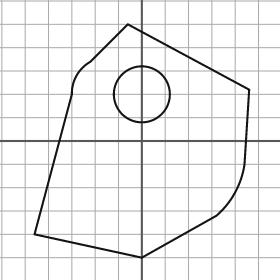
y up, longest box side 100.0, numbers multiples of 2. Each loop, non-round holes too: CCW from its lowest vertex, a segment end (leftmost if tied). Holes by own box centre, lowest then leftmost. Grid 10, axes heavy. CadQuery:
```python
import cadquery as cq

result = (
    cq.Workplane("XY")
    .moveTo(0.0, -50.0)
    .lineTo(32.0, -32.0)
    .threePointArc((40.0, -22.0), (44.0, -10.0))
    .lineTo(46.0, 22.0)
    .lineTo(-6.0, 50.0)
    .lineTo(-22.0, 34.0)
    .threePointArc((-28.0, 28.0), (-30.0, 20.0))
    .lineTo(-46.0, -40.0)
    .close()
    .moveTo(0.0, 20.0)
    .circle(12.0)
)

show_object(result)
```